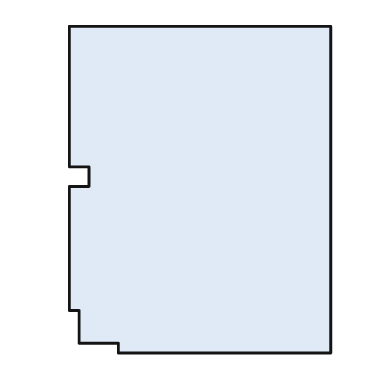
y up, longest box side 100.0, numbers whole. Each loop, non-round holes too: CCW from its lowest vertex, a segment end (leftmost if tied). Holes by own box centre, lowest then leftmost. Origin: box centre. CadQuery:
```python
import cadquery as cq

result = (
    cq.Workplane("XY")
    .moveTo(-25.0, -50.0)
    .lineTo(40.0, -50.0)
    .lineTo(40.0, 50.0)
    .lineTo(-40.0, 50.0)
    .lineTo(-40.0, 7.0)
    .lineTo(-34.0, 7.0)
    .lineTo(-34.0, 1.0)
    .lineTo(-40.0, 1.0)
    .lineTo(-40.0, -37.0)
    .lineTo(-37.0, -37.0)
    .lineTo(-37.0, -47.0)
    .lineTo(-25.0, -47.0)
    .close()
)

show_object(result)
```